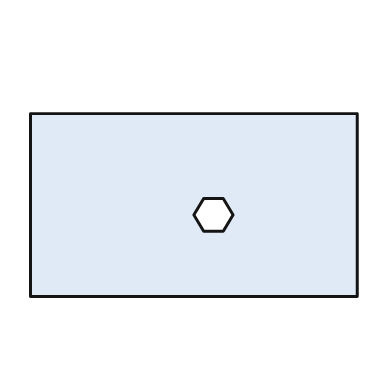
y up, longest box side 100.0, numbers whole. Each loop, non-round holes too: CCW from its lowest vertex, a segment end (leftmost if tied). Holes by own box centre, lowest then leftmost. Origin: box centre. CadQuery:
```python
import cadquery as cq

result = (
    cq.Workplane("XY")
    .moveTo(-50.0, -28.0)
    .lineTo(50.0, -28.0)
    .lineTo(50.0, 28.0)
    .lineTo(-50.0, 28.0)
    .close()
    .moveTo(3.0, -8.0)
    .lineTo(9.0, -8.0)
    .lineTo(12.0, -3.0)
    .lineTo(9.0, 2.0)
    .lineTo(3.0, 2.0)
    .lineTo(0.0, -3.0)
    .close()
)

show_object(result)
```